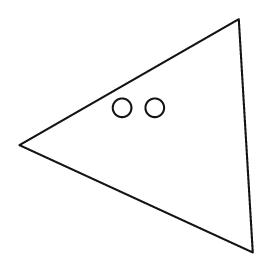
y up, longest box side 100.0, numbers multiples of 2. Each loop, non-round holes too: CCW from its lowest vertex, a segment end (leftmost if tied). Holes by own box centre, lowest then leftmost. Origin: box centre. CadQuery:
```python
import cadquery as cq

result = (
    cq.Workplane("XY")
    .moveTo(50.0, -50.0)
    .lineTo(44.0, 50.0)
    .lineTo(-50.0, -4.0)
    .close()
    .moveTo(-6.0, 12.0)
    .circle(4.0)
    .moveTo(8.0, 12.0)
    .circle(4.0)
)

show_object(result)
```